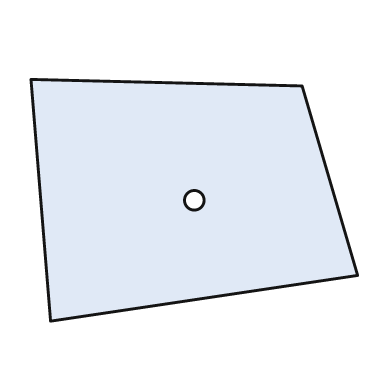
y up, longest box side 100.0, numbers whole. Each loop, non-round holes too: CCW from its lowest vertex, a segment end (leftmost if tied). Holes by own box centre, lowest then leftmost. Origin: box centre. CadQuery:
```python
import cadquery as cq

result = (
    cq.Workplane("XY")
    .moveTo(-44.0, -37.0)
    .lineTo(50.0, -23.0)
    .lineTo(33.0, 35.0)
    .lineTo(-50.0, 37.0)
    .close()
    .moveTo(0.0, 0.0)
    .circle(3.0)
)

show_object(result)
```